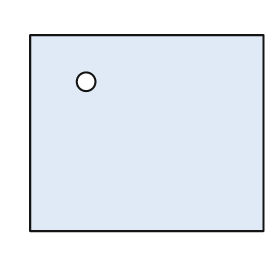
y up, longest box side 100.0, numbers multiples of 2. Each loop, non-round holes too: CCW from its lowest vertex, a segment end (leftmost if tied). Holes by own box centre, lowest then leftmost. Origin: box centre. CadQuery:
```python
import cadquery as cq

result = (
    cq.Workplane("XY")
    .moveTo(-50.0, -42.0)
    .lineTo(50.0, -42.0)
    .lineTo(50.0, 42.0)
    .lineTo(-50.0, 42.0)
    .close()
    .moveTo(-26.0, 22.0)
    .circle(4.0)
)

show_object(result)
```